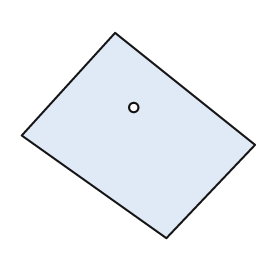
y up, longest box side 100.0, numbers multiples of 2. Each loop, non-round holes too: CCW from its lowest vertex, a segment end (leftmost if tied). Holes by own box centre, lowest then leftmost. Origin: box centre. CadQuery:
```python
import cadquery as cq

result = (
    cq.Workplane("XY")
    .moveTo(12.0, -44.0)
    .lineTo(50.0, -4.0)
    .lineTo(-10.0, 44.0)
    .lineTo(-50.0, 0.0)
    .close()
    .moveTo(-2.0, 12.0)
    .circle(2.0)
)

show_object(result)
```